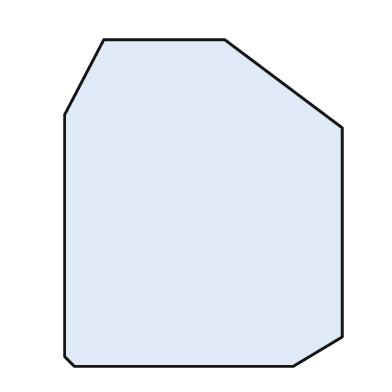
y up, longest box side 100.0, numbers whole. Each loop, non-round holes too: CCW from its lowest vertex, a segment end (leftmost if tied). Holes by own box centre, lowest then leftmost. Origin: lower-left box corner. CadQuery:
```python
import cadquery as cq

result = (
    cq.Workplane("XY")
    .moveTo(3.0, 0.0)
    .lineTo(70.0, 0.0)
    .lineTo(85.0, 9.0)
    .lineTo(85.0, 73.0)
    .lineTo(49.0, 100.0)
    .lineTo(12.0, 100.0)
    .lineTo(0.0, 77.0)
    .lineTo(0.0, 3.0)
    .close()
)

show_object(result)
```